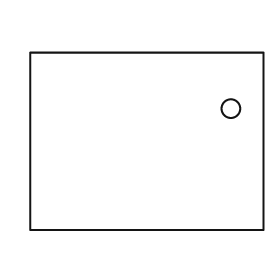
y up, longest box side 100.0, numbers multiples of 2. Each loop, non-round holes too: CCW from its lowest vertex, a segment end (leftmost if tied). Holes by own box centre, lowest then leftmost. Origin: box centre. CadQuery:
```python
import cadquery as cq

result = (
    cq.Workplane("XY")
    .moveTo(-50.0, -38.0)
    .lineTo(50.0, -38.0)
    .lineTo(50.0, 38.0)
    .lineTo(-50.0, 38.0)
    .close()
    .moveTo(36.0, 14.0)
    .circle(4.0)
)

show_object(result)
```